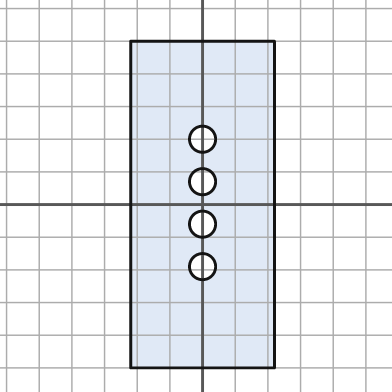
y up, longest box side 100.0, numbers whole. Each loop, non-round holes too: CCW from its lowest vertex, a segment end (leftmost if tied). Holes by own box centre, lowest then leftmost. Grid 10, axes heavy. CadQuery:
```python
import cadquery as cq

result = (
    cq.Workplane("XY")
    .moveTo(-22.0, -50.0)
    .lineTo(22.0, -50.0)
    .lineTo(22.0, 50.0)
    .lineTo(-22.0, 50.0)
    .close()
    .moveTo(0.0, -19.0)
    .circle(4.0)
    .moveTo(0.0, -6.0)
    .circle(4.0)
    .moveTo(0.0, 7.0)
    .circle(4.0)
    .moveTo(0.0, 20.0)
    .circle(4.0)
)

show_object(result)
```